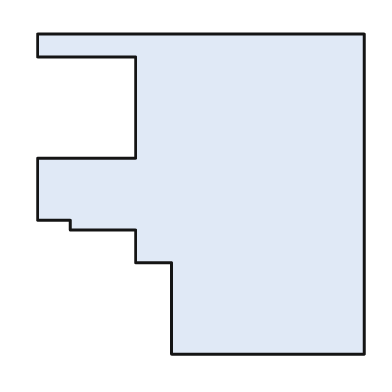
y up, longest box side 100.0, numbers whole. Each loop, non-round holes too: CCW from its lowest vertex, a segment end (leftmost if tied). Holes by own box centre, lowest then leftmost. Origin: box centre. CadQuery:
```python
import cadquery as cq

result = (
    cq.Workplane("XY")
    .moveTo(-9.0, -49.0)
    .lineTo(50.0, -49.0)
    .lineTo(50.0, 49.0)
    .lineTo(-50.0, 49.0)
    .lineTo(-50.0, 42.0)
    .lineTo(-20.0, 42.0)
    .lineTo(-20.0, 11.0)
    .lineTo(-50.0, 11.0)
    .lineTo(-50.0, -8.0)
    .lineTo(-40.0, -8.0)
    .lineTo(-40.0, -11.0)
    .lineTo(-20.0, -11.0)
    .lineTo(-20.0, -21.0)
    .lineTo(-9.0, -21.0)
    .close()
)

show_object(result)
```